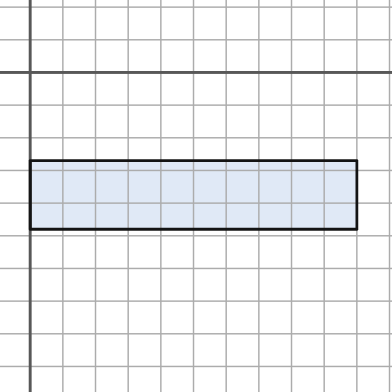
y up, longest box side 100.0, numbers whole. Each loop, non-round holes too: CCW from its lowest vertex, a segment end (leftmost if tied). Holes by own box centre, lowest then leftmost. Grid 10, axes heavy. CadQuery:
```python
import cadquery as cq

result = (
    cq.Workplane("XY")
    .moveTo(0.0, -48.0)
    .lineTo(100.0, -48.0)
    .lineTo(100.0, -27.0)
    .lineTo(0.0, -27.0)
    .close()
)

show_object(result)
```